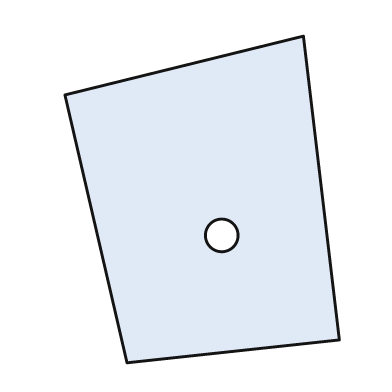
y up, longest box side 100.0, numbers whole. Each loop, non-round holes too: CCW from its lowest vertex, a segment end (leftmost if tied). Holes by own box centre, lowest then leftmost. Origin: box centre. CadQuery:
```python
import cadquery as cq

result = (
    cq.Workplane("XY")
    .moveTo(-23.0, -50.0)
    .lineTo(42.0, -43.0)
    .lineTo(31.0, 50.0)
    .lineTo(-42.0, 32.0)
    .close()
    .moveTo(6.0, -11.0)
    .circle(5.0)
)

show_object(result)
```